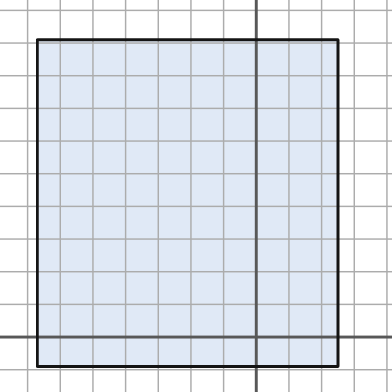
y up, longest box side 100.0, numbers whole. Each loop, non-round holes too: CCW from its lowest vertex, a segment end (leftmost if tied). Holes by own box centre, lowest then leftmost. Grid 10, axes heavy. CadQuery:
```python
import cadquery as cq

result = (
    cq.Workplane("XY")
    .moveTo(-67.0, -9.0)
    .lineTo(25.0, -9.0)
    .lineTo(25.0, 91.0)
    .lineTo(-67.0, 91.0)
    .close()
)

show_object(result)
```